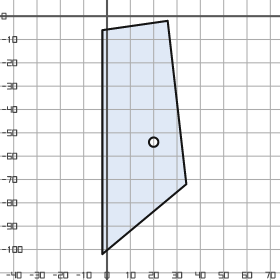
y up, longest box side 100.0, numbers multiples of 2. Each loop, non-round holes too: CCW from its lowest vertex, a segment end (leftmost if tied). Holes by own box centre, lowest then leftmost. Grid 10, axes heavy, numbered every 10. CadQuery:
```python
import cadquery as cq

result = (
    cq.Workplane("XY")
    .moveTo(-2.0, -102.0)
    .lineTo(34.0, -72.0)
    .lineTo(26.0, -2.0)
    .lineTo(-2.0, -6.0)
    .close()
    .moveTo(20.0, -54.0)
    .circle(2.0)
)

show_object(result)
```